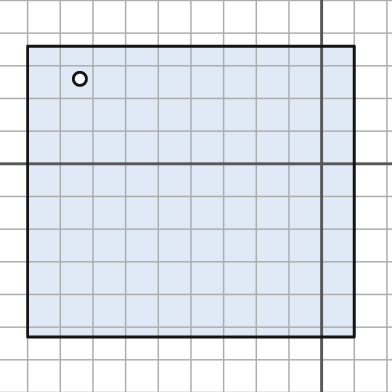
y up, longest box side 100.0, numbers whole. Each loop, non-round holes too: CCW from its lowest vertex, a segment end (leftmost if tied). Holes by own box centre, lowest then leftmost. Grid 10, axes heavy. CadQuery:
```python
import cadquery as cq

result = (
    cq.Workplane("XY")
    .moveTo(-90.0, -53.0)
    .lineTo(10.0, -53.0)
    .lineTo(10.0, 36.0)
    .lineTo(-90.0, 36.0)
    .close()
    .moveTo(-74.0, 26.0)
    .circle(2.0)
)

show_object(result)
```